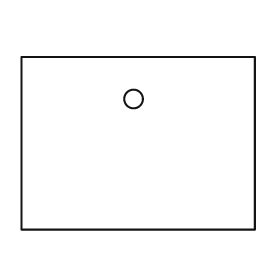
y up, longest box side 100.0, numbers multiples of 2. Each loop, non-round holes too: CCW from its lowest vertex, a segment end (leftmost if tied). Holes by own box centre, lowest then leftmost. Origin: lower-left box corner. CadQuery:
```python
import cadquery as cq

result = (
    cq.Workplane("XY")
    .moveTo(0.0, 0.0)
    .lineTo(100.0, 0.0)
    .lineTo(100.0, 74.0)
    .lineTo(0.0, 74.0)
    .close()
    .moveTo(48.0, 56.0)
    .circle(4.0)
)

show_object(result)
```